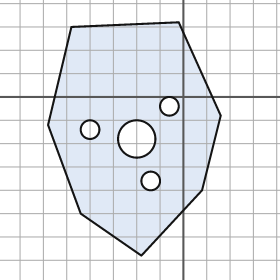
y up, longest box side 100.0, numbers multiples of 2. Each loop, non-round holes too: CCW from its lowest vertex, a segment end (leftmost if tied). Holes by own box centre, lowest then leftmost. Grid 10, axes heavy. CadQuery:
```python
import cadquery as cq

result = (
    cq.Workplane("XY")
    .moveTo(-18.0, -68.0)
    .lineTo(8.0, -40.0)
    .lineTo(16.0, -8.0)
    .lineTo(-2.0, 32.0)
    .lineTo(-48.0, 30.0)
    .lineTo(-58.0, -12.0)
    .lineTo(-44.0, -50.0)
    .close()
    .moveTo(-14.0, -36.0)
    .circle(4.0)
    .moveTo(-20.0, -18.0)
    .circle(8.0)
    .moveTo(-40.0, -14.0)
    .circle(4.0)
    .moveTo(-6.0, -4.0)
    .circle(4.0)
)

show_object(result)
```